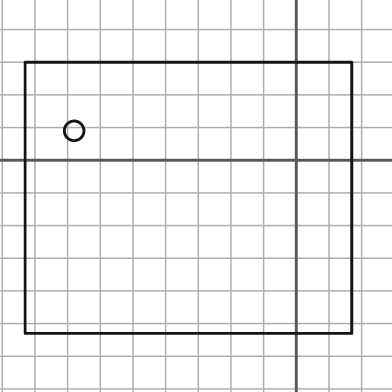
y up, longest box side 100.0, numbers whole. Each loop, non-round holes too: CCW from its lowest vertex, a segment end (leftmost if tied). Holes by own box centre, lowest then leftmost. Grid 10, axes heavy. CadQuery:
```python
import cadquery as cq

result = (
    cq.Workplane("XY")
    .moveTo(-83.0, -53.0)
    .lineTo(17.0, -53.0)
    .lineTo(17.0, 30.0)
    .lineTo(-83.0, 30.0)
    .close()
    .moveTo(-68.0, 9.0)
    .circle(3.0)
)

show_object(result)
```